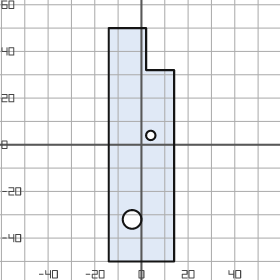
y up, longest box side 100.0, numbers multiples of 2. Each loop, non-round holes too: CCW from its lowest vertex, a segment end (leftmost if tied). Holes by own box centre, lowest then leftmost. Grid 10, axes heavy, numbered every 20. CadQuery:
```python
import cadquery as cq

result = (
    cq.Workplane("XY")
    .moveTo(-14.0, -50.0)
    .lineTo(14.0, -50.0)
    .lineTo(14.0, 32.0)
    .lineTo(2.0, 32.0)
    .lineTo(2.0, 50.0)
    .lineTo(-14.0, 50.0)
    .close()
    .moveTo(-4.0, -32.0)
    .circle(4.0)
    .moveTo(4.0, 4.0)
    .circle(2.0)
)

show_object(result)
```